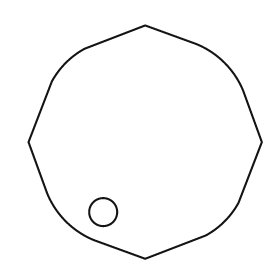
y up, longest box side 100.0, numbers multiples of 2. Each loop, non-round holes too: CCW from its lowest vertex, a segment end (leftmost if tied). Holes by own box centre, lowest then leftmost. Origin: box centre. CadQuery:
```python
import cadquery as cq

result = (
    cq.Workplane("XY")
    .moveTo(0.0, -50.0)
    .lineTo(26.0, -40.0)
    .threePointArc((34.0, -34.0), (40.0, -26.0))
    .lineTo(50.0, 0.0)
    .lineTo(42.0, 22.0)
    .threePointArc((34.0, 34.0), (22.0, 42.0))
    .lineTo(0.0, 50.0)
    .lineTo(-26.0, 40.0)
    .threePointArc((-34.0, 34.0), (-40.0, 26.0))
    .lineTo(-50.0, 0.0)
    .lineTo(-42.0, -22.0)
    .threePointArc((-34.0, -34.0), (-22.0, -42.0))
    .close()
    .moveTo(-18.0, -30.0)
    .circle(6.0)
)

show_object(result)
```